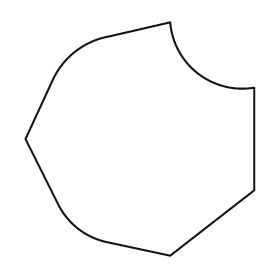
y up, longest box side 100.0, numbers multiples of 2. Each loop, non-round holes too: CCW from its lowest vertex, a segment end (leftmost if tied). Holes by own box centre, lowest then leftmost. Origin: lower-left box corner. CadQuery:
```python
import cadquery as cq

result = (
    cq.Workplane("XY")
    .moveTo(62.0, 0.0)
    .lineTo(98.0, 28.0)
    .lineTo(98.0, 72.0)
    .threePointArc((74.0, 78.0), (62.0, 100.0))
    .lineTo(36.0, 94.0)
    .threePointArc((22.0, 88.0), (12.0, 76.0))
    .lineTo(0.0, 50.0)
    .lineTo(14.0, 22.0)
    .threePointArc((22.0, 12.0), (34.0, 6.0))
    .close()
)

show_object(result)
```